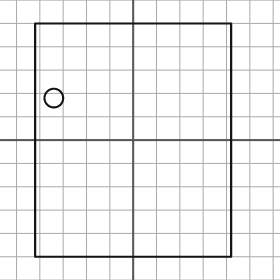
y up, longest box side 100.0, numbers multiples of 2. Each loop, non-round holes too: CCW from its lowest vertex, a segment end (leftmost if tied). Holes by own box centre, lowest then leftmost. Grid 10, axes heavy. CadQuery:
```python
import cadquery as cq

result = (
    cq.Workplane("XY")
    .moveTo(-42.0, -50.0)
    .lineTo(42.0, -50.0)
    .lineTo(42.0, 50.0)
    .lineTo(-42.0, 50.0)
    .close()
    .moveTo(-34.0, 18.0)
    .circle(4.0)
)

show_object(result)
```